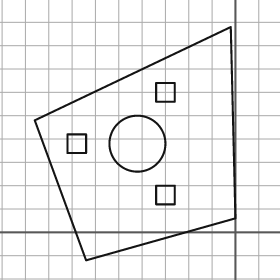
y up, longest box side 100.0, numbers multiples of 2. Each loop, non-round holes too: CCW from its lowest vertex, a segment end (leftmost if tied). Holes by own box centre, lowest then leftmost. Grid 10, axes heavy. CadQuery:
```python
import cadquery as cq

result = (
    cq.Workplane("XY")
    .moveTo(-64.0, -12.0)
    .lineTo(0.0, 6.0)
    .lineTo(-2.0, 88.0)
    .lineTo(-86.0, 48.0)
    .close()
    .moveTo(-34.0, 12.0)
    .lineTo(-26.0, 12.0)
    .lineTo(-26.0, 20.0)
    .lineTo(-34.0, 20.0)
    .close()
    .moveTo(-72.0, 34.0)
    .lineTo(-64.0, 34.0)
    .lineTo(-64.0, 42.0)
    .lineTo(-72.0, 42.0)
    .close()
    .moveTo(-42.0, 38.0)
    .circle(12.0)
    .moveTo(-34.0, 56.0)
    .lineTo(-26.0, 56.0)
    .lineTo(-26.0, 64.0)
    .lineTo(-34.0, 64.0)
    .close()
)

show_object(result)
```